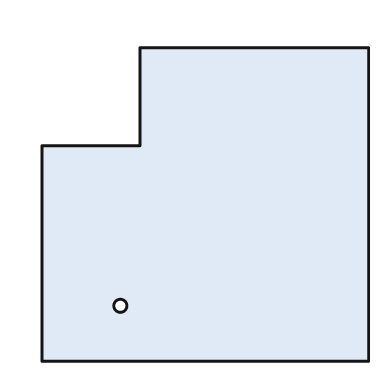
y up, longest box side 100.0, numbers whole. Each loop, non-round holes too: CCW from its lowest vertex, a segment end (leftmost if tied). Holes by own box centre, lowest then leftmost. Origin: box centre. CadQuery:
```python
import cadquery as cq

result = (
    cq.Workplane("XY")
    .moveTo(-50.0, -48.0)
    .lineTo(50.0, -48.0)
    .lineTo(50.0, 48.0)
    .lineTo(-20.0, 48.0)
    .lineTo(-20.0, 18.0)
    .lineTo(-50.0, 18.0)
    .close()
    .moveTo(-26.0, -31.0)
    .circle(2.0)
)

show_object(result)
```